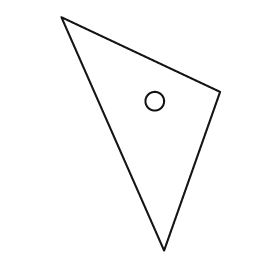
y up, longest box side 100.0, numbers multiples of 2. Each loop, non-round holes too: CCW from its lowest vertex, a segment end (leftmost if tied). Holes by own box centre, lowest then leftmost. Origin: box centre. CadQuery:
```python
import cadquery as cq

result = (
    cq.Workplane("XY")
    .moveTo(10.0, -50.0)
    .lineTo(34.0, 18.0)
    .lineTo(-34.0, 50.0)
    .close()
    .moveTo(6.0, 14.0)
    .circle(4.0)
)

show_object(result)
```